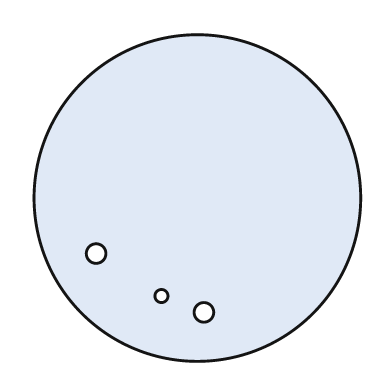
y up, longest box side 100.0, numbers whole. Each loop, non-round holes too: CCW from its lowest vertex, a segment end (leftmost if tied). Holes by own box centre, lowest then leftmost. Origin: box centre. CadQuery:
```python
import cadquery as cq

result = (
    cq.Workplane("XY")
    .moveTo(0.0, 0.0)
    .circle(50.0)
    .moveTo(2.0, -35.0)
    .circle(3.0)
    .moveTo(-11.0, -30.0)
    .circle(2.0)
    .moveTo(-31.0, -17.0)
    .circle(3.0)
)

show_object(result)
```